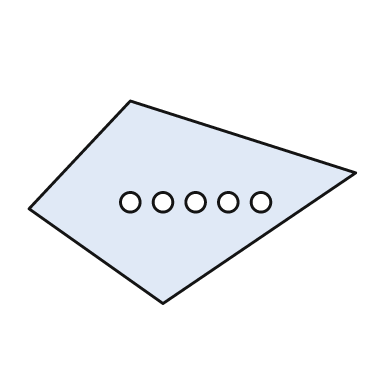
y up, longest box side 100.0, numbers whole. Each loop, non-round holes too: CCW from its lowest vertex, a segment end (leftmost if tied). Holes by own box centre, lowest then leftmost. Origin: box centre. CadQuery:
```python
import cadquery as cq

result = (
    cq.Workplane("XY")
    .moveTo(-9.0, -31.0)
    .lineTo(50.0, 9.0)
    .lineTo(-19.0, 31.0)
    .lineTo(-50.0, -2.0)
    .close()
    .moveTo(-19.0, 0.0)
    .circle(3.0)
    .moveTo(-9.0, 0.0)
    .circle(3.0)
    .moveTo(1.0, 0.0)
    .circle(3.0)
    .moveTo(11.0, 0.0)
    .circle(3.0)
    .moveTo(21.0, 0.0)
    .circle(3.0)
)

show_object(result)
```